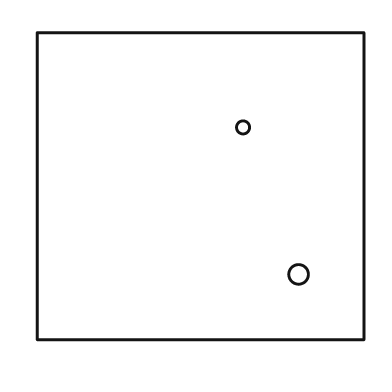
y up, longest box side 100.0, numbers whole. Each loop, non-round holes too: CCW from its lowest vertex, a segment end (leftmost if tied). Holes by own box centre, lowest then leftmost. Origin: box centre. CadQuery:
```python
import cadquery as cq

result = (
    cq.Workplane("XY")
    .moveTo(-50.0, -47.0)
    .lineTo(50.0, -47.0)
    .lineTo(50.0, 47.0)
    .lineTo(-50.0, 47.0)
    .close()
    .moveTo(30.0, -27.0)
    .circle(3.0)
    .moveTo(13.0, 18.0)
    .circle(2.0)
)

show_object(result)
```